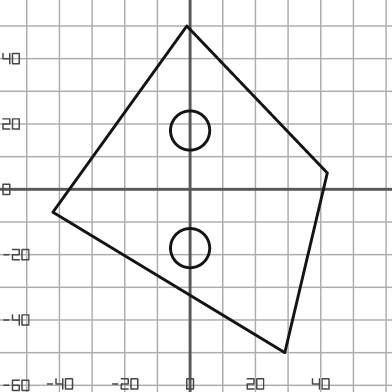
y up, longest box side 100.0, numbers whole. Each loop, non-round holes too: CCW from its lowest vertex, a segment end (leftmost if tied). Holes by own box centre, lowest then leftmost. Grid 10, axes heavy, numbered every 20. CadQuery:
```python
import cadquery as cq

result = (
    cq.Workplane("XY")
    .moveTo(29.0, -50.0)
    .lineTo(42.0, 5.0)
    .lineTo(-1.0, 50.0)
    .lineTo(-42.0, -7.0)
    .close()
    .moveTo(0.0, -18.0)
    .circle(6.0)
    .moveTo(0.0, 18.0)
    .circle(6.0)
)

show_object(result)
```